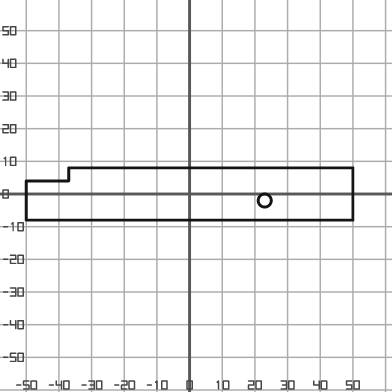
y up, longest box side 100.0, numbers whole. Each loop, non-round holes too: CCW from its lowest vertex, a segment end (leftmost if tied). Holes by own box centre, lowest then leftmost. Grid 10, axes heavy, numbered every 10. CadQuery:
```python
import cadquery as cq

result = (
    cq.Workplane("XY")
    .moveTo(-50.0, -8.0)
    .lineTo(50.0, -8.0)
    .lineTo(50.0, 8.0)
    .lineTo(-37.0, 8.0)
    .lineTo(-37.0, 4.0)
    .lineTo(-50.0, 4.0)
    .close()
    .moveTo(23.0, -2.0)
    .circle(2.0)
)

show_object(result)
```